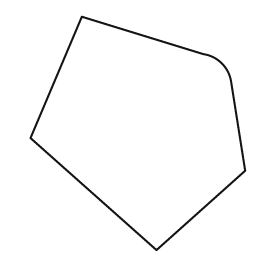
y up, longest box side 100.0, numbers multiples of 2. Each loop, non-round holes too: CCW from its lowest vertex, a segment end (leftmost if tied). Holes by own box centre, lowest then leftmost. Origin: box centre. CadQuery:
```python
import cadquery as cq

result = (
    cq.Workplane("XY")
    .moveTo(8.0, -50.0)
    .lineTo(46.0, -16.0)
    .lineTo(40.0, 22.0)
    .threePointArc((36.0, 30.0), (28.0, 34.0))
    .lineTo(-24.0, 50.0)
    .lineTo(-46.0, -2.0)
    .close()
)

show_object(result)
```